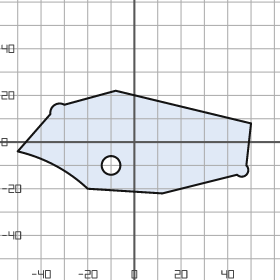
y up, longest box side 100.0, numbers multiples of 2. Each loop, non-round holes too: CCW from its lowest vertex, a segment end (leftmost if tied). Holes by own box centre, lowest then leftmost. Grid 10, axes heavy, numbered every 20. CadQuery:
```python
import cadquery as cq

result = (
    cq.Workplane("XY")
    .moveTo(12.0, -22.0)
    .lineTo(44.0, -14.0)
    .threePointArc((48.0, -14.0), (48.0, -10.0))
    .lineTo(50.0, 8.0)
    .lineTo(-8.0, 22.0)
    .lineTo(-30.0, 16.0)
    .threePointArc((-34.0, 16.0), (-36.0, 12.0))
    .lineTo(-50.0, -4.0)
    .threePointArc((-34.0, -10.0), (-20.0, -20.0))
    .close()
    .moveTo(-10.0, -10.0)
    .circle(4.0)
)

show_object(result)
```